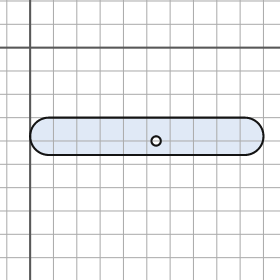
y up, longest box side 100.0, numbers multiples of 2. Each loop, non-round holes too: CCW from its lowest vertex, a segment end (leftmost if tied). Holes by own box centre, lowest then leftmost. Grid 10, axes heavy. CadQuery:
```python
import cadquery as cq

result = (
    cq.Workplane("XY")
    .moveTo(8.0, -46.0)
    .lineTo(92.0, -46.0)
    .threePointArc((100.0, -38.0), (92.0, -30.0))
    .lineTo(8.0, -30.0)
    .threePointArc((0.0, -38.0), (8.0, -46.0))
    .close()
    .moveTo(54.0, -40.0)
    .circle(2.0)
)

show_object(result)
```